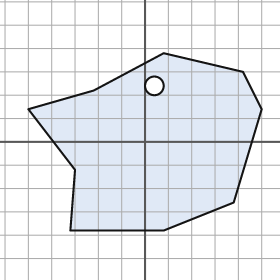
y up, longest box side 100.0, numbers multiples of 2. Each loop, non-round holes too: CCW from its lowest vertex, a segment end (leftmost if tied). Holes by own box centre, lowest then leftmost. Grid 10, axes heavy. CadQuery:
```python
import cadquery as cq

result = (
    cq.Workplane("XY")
    .moveTo(-32.0, -38.0)
    .lineTo(8.0, -38.0)
    .lineTo(38.0, -26.0)
    .lineTo(50.0, 14.0)
    .lineTo(42.0, 30.0)
    .lineTo(8.0, 38.0)
    .lineTo(-22.0, 22.0)
    .lineTo(-50.0, 14.0)
    .lineTo(-30.0, -12.0)
    .close()
    .moveTo(4.0, 24.0)
    .circle(4.0)
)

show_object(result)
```